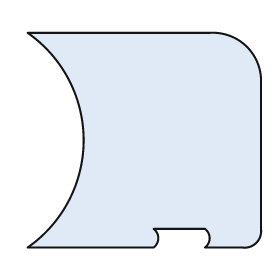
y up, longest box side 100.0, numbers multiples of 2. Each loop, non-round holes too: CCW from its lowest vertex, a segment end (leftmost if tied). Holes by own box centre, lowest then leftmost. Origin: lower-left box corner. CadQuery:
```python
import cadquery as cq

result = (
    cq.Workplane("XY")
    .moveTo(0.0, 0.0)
    .lineTo(54.0, 0.0)
    .threePointArc((56.0, 4.0), (54.0, 8.0))
    .lineTo(76.0, 8.0)
    .threePointArc((78.0, 4.0), (76.0, 0.0))
    .lineTo(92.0, 0.0)
    .threePointArc((98.0, 2.0), (100.0, 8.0))
    .lineTo(100.0, 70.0)
    .threePointArc((94.0, 86.0), (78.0, 92.0))
    .lineTo(0.0, 92.0)
    .threePointArc((24.0, 46.0), (0.0, 0.0))
    .close()
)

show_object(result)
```